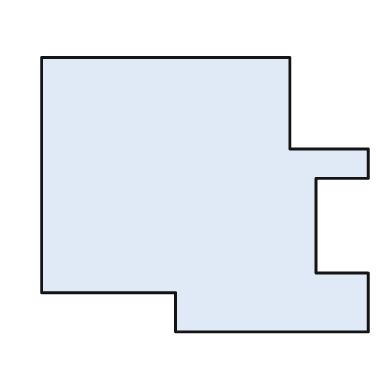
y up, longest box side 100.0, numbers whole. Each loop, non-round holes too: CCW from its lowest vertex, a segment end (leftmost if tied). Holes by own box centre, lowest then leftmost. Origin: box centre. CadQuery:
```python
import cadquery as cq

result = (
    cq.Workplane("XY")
    .moveTo(-9.0, -42.0)
    .lineTo(50.0, -42.0)
    .lineTo(50.0, -24.0)
    .lineTo(34.0, -24.0)
    .lineTo(34.0, 5.0)
    .lineTo(50.0, 5.0)
    .lineTo(50.0, 14.0)
    .lineTo(26.0, 14.0)
    .lineTo(26.0, 42.0)
    .lineTo(-50.0, 42.0)
    .lineTo(-50.0, -30.0)
    .lineTo(-9.0, -30.0)
    .close()
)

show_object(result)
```